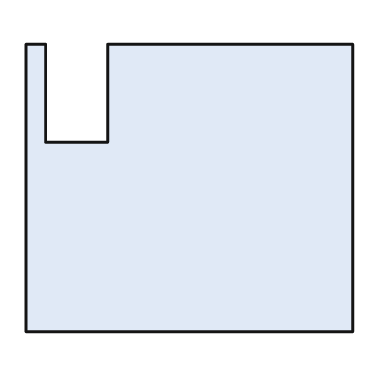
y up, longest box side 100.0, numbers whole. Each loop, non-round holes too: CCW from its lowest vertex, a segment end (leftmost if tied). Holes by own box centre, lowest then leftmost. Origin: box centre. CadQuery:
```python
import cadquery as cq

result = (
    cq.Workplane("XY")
    .moveTo(-50.0, -44.0)
    .lineTo(50.0, -44.0)
    .lineTo(50.0, 44.0)
    .lineTo(-25.0, 44.0)
    .lineTo(-25.0, 14.0)
    .lineTo(-44.0, 14.0)
    .lineTo(-44.0, 44.0)
    .lineTo(-50.0, 44.0)
    .close()
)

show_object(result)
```